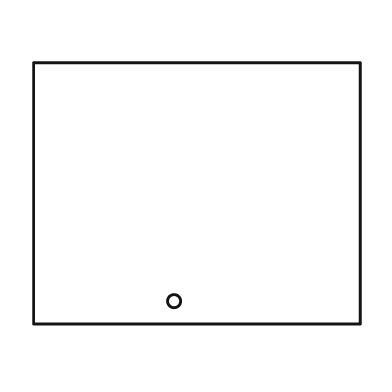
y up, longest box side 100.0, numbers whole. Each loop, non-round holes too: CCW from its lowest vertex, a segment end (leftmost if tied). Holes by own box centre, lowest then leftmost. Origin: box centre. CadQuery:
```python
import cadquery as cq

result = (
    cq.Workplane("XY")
    .moveTo(-50.0, -40.0)
    .lineTo(50.0, -40.0)
    .lineTo(50.0, 40.0)
    .lineTo(-50.0, 40.0)
    .close()
    .moveTo(-7.0, -33.0)
    .circle(2.0)
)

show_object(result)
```